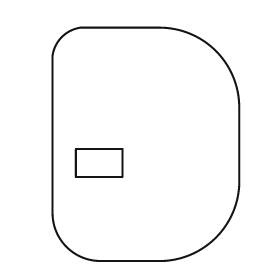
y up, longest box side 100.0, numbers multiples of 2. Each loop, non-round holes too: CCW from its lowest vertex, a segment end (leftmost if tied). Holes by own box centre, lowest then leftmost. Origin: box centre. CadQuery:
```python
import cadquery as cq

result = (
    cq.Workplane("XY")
    .moveTo(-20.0, -50.0)
    .lineTo(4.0, -50.0)
    .threePointArc((30.0, -40.0), (40.0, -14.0))
    .lineTo(40.0, 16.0)
    .threePointArc((30.0, 40.0), (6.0, 50.0))
    .lineTo(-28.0, 50.0)
    .threePointArc((-36.0, 46.0), (-40.0, 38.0))
    .lineTo(-40.0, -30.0)
    .threePointArc((-34.0, -44.0), (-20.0, -50.0))
    .close()
    .moveTo(-30.0, -14.0)
    .lineTo(-10.0, -14.0)
    .lineTo(-10.0, -2.0)
    .lineTo(-30.0, -2.0)
    .close()
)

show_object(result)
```